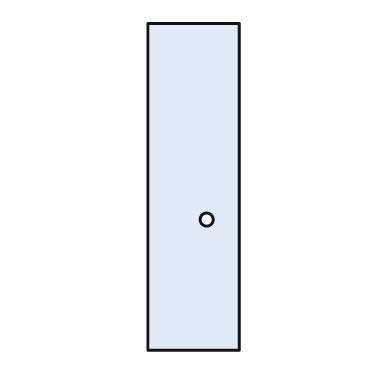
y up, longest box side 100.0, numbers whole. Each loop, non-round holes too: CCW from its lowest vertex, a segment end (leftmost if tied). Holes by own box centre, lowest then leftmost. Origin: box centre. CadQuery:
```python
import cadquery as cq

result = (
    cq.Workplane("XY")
    .moveTo(-14.0, -50.0)
    .lineTo(14.0, -50.0)
    .lineTo(14.0, 50.0)
    .lineTo(-14.0, 50.0)
    .close()
    .moveTo(4.0, -10.0)
    .circle(2.0)
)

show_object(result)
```